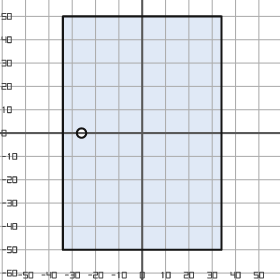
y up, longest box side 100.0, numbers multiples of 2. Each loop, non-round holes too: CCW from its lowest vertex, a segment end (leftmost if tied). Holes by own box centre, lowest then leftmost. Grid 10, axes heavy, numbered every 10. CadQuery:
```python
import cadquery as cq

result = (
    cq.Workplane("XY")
    .moveTo(-34.0, -50.0)
    .lineTo(34.0, -50.0)
    .lineTo(34.0, 50.0)
    .lineTo(-34.0, 50.0)
    .close()
    .moveTo(-26.0, 0.0)
    .circle(2.0)
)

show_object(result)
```